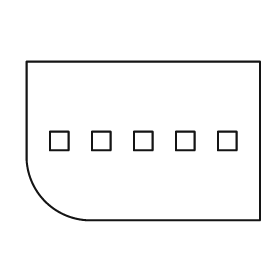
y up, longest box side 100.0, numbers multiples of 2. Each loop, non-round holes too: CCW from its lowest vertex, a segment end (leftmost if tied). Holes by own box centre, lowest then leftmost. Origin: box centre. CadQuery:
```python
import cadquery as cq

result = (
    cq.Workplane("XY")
    .moveTo(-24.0, -34.0)
    .lineTo(50.0, -34.0)
    .lineTo(50.0, 34.0)
    .lineTo(-50.0, 34.0)
    .lineTo(-50.0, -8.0)
    .threePointArc((-42.0, -26.0), (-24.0, -34.0))
    .close()
    .moveTo(-40.0, -4.0)
    .lineTo(-32.0, -4.0)
    .lineTo(-32.0, 4.0)
    .lineTo(-40.0, 4.0)
    .close()
    .moveTo(-22.0, -4.0)
    .lineTo(-14.0, -4.0)
    .lineTo(-14.0, 4.0)
    .lineTo(-22.0, 4.0)
    .close()
    .moveTo(-4.0, -4.0)
    .lineTo(4.0, -4.0)
    .lineTo(4.0, 4.0)
    .lineTo(-4.0, 4.0)
    .close()
    .moveTo(14.0, -4.0)
    .lineTo(22.0, -4.0)
    .lineTo(22.0, 4.0)
    .lineTo(14.0, 4.0)
    .close()
    .moveTo(32.0, -4.0)
    .lineTo(40.0, -4.0)
    .lineTo(40.0, 4.0)
    .lineTo(32.0, 4.0)
    .close()
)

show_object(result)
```